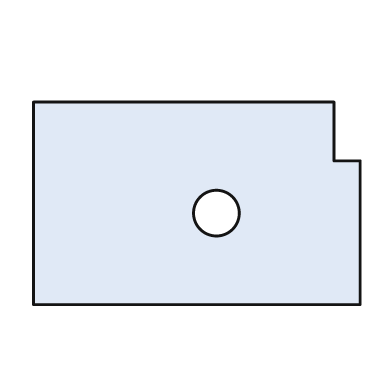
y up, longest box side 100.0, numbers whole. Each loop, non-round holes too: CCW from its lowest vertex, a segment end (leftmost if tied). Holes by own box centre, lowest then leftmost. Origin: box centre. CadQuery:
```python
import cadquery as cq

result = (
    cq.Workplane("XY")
    .moveTo(-50.0, -31.0)
    .lineTo(50.0, -31.0)
    .lineTo(50.0, 13.0)
    .lineTo(42.0, 13.0)
    .lineTo(42.0, 31.0)
    .lineTo(-50.0, 31.0)
    .close()
    .moveTo(6.0, -3.0)
    .circle(7.0)
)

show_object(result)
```